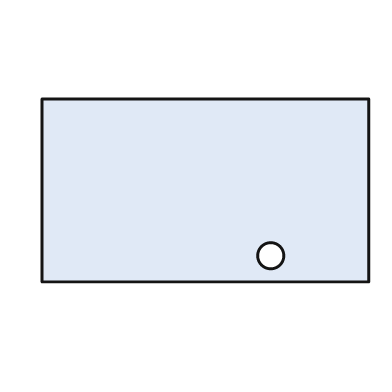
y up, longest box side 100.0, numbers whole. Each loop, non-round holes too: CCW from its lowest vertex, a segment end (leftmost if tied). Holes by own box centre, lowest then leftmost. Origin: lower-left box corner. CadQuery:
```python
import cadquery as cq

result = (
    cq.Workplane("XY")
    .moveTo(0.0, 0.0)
    .lineTo(100.0, 0.0)
    .lineTo(100.0, 56.0)
    .lineTo(0.0, 56.0)
    .close()
    .moveTo(70.0, 8.0)
    .circle(4.0)
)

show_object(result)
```